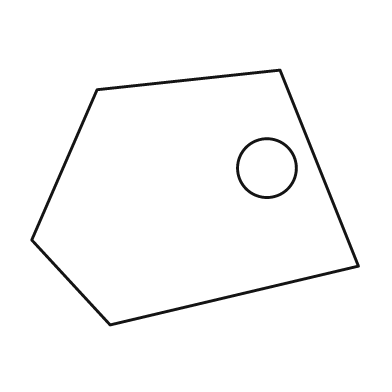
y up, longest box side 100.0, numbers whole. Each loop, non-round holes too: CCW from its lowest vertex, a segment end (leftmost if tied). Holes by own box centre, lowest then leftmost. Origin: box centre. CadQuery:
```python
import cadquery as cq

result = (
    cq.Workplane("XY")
    .moveTo(-26.0, -39.0)
    .lineTo(50.0, -21.0)
    .lineTo(26.0, 39.0)
    .lineTo(-30.0, 33.0)
    .lineTo(-50.0, -13.0)
    .close()
    .moveTo(22.0, 9.0)
    .circle(9.0)
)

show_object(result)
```